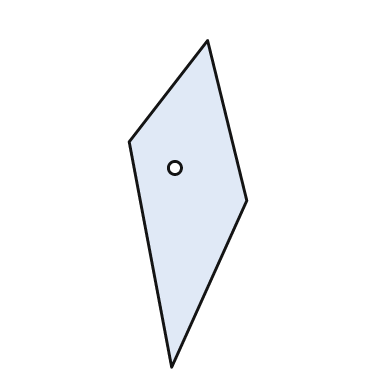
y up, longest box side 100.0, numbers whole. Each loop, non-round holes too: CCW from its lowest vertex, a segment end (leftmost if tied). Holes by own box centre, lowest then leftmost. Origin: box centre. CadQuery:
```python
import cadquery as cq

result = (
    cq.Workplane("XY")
    .moveTo(-5.0, -50.0)
    .lineTo(18.0, 1.0)
    .lineTo(6.0, 50.0)
    .lineTo(-18.0, 19.0)
    .close()
    .moveTo(-4.0, 11.0)
    .circle(2.0)
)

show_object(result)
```